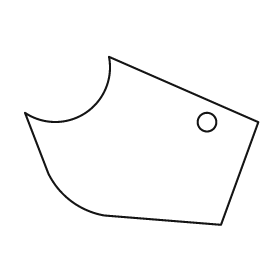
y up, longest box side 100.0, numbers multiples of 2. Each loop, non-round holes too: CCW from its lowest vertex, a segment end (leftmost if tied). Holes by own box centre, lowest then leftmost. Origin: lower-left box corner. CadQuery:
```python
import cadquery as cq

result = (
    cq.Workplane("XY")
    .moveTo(84.0, 0.0)
    .lineTo(100.0, 44.0)
    .lineTo(36.0, 72.0)
    .threePointArc((26.0, 48.0), (0.0, 48.0))
    .lineTo(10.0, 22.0)
    .threePointArc((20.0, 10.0), (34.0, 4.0))
    .close()
    .moveTo(78.0, 44.0)
    .circle(4.0)
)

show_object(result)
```